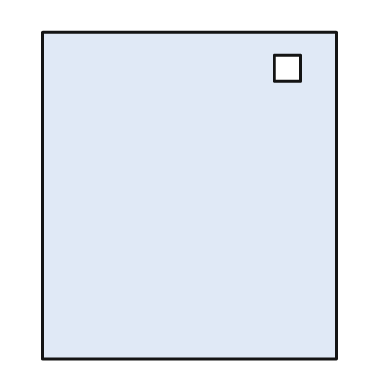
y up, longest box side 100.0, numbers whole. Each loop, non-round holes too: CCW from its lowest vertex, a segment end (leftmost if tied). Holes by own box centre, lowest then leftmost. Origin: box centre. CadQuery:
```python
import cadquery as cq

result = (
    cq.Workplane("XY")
    .moveTo(-45.0, -50.0)
    .lineTo(45.0, -50.0)
    .lineTo(45.0, 50.0)
    .lineTo(-45.0, 50.0)
    .close()
    .moveTo(26.0, 35.0)
    .lineTo(34.0, 35.0)
    .lineTo(34.0, 43.0)
    .lineTo(26.0, 43.0)
    .close()
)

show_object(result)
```